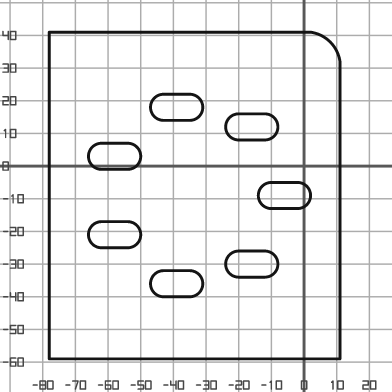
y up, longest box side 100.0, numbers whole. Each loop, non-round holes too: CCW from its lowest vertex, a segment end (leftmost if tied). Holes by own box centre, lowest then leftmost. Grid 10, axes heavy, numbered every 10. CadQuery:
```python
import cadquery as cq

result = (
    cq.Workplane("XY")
    .moveTo(-78.0, -59.0)
    .lineTo(11.0, -59.0)
    .lineTo(11.0, 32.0)
    .threePointArc((8.0, 38.0), (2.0, 41.0))
    .lineTo(-78.0, 41.0)
    .close()
    .moveTo(-43.0, -40.0)
    .lineTo(-35.0, -40.0)
    .threePointArc((-31.0, -36.0), (-35.0, -32.0))
    .lineTo(-43.0, -32.0)
    .threePointArc((-47.0, -36.0), (-43.0, -40.0))
    .close()
    .moveTo(-20.0, -34.0)
    .lineTo(-12.0, -34.0)
    .threePointArc((-8.0, -30.0), (-12.0, -26.0))
    .lineTo(-20.0, -26.0)
    .threePointArc((-24.0, -30.0), (-20.0, -34.0))
    .close()
    .moveTo(-62.0, -25.0)
    .lineTo(-54.0, -25.0)
    .threePointArc((-50.0, -21.0), (-54.0, -17.0))
    .lineTo(-62.0, -17.0)
    .threePointArc((-66.0, -21.0), (-62.0, -25.0))
    .close()
    .moveTo(-10.0, -13.0)
    .lineTo(-2.0, -13.0)
    .threePointArc((2.0, -9.0), (-2.0, -5.0))
    .lineTo(-10.0, -5.0)
    .threePointArc((-14.0, -9.0), (-10.0, -13.0))
    .close()
    .moveTo(-62.0, -1.0)
    .lineTo(-54.0, -1.0)
    .threePointArc((-50.0, 3.0), (-54.0, 7.0))
    .lineTo(-62.0, 7.0)
    .threePointArc((-66.0, 3.0), (-62.0, -1.0))
    .close()
    .moveTo(-20.0, 8.0)
    .lineTo(-12.0, 8.0)
    .threePointArc((-8.0, 12.0), (-12.0, 16.0))
    .lineTo(-20.0, 16.0)
    .threePointArc((-24.0, 12.0), (-20.0, 8.0))
    .close()
    .moveTo(-43.0, 14.0)
    .lineTo(-35.0, 14.0)
    .threePointArc((-31.0, 18.0), (-35.0, 22.0))
    .lineTo(-43.0, 22.0)
    .threePointArc((-47.0, 18.0), (-43.0, 14.0))
    .close()
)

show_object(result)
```